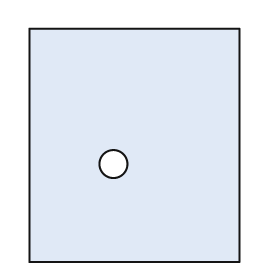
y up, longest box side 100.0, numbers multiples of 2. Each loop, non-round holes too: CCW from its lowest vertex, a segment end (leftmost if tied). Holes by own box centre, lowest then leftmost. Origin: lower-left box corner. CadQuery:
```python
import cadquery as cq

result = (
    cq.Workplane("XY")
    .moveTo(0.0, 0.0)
    .lineTo(90.0, 0.0)
    .lineTo(90.0, 100.0)
    .lineTo(0.0, 100.0)
    .close()
    .moveTo(36.0, 42.0)
    .circle(6.0)
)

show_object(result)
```